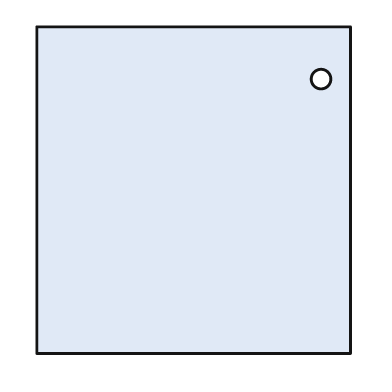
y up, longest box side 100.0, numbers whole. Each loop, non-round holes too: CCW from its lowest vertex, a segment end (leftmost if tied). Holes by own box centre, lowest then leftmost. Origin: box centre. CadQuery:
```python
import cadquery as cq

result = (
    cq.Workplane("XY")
    .moveTo(-48.0, -50.0)
    .lineTo(48.0, -50.0)
    .lineTo(48.0, 50.0)
    .lineTo(-48.0, 50.0)
    .close()
    .moveTo(39.0, 34.0)
    .circle(3.0)
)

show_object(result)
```